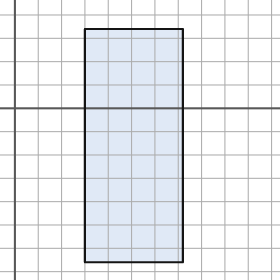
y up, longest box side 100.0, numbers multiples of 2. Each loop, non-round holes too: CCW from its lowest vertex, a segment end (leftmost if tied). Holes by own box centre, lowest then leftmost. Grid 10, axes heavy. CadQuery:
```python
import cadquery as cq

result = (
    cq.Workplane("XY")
    .moveTo(30.0, -66.0)
    .lineTo(72.0, -66.0)
    .lineTo(72.0, 34.0)
    .lineTo(30.0, 34.0)
    .close()
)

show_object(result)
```